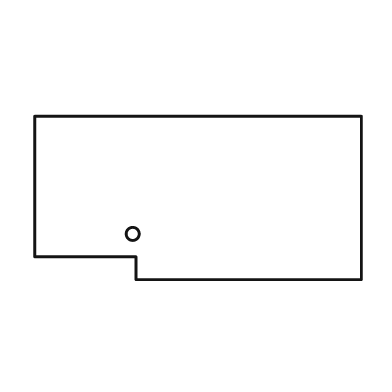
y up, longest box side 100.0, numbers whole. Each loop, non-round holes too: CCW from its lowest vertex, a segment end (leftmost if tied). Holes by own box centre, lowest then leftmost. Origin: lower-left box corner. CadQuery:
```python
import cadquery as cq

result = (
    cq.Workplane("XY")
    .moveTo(31.0, 0.0)
    .lineTo(100.0, 0.0)
    .lineTo(100.0, 50.0)
    .lineTo(0.0, 50.0)
    .lineTo(0.0, 7.0)
    .lineTo(31.0, 7.0)
    .close()
    .moveTo(30.0, 14.0)
    .circle(2.0)
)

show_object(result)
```